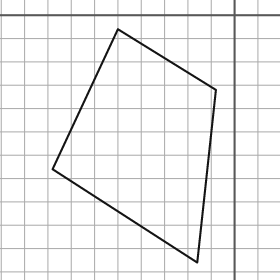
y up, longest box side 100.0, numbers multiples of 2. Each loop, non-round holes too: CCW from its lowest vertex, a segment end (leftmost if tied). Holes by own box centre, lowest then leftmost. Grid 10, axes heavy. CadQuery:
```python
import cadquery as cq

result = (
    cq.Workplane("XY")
    .moveTo(-16.0, -106.0)
    .lineTo(-8.0, -32.0)
    .lineTo(-50.0, -6.0)
    .lineTo(-78.0, -66.0)
    .close()
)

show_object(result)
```